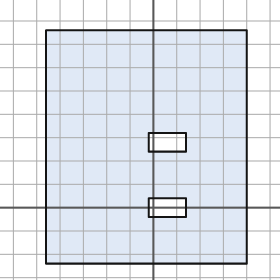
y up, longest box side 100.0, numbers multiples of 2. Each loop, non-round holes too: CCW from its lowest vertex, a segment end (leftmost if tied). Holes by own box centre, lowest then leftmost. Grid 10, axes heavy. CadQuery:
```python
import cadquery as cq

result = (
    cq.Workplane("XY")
    .moveTo(-46.0, -24.0)
    .lineTo(40.0, -24.0)
    .lineTo(40.0, 76.0)
    .lineTo(-46.0, 76.0)
    .close()
    .moveTo(-2.0, -4.0)
    .lineTo(14.0, -4.0)
    .lineTo(14.0, 4.0)
    .lineTo(-2.0, 4.0)
    .close()
    .moveTo(-2.0, 24.0)
    .lineTo(14.0, 24.0)
    .lineTo(14.0, 32.0)
    .lineTo(-2.0, 32.0)
    .close()
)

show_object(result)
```